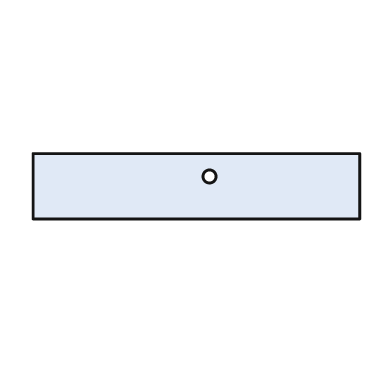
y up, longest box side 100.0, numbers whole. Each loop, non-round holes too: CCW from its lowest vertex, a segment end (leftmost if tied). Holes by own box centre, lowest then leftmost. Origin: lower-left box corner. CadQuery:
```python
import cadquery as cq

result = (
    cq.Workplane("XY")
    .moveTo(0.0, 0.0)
    .lineTo(100.0, 0.0)
    .lineTo(100.0, 20.0)
    .lineTo(0.0, 20.0)
    .close()
    .moveTo(54.0, 13.0)
    .circle(2.0)
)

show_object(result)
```